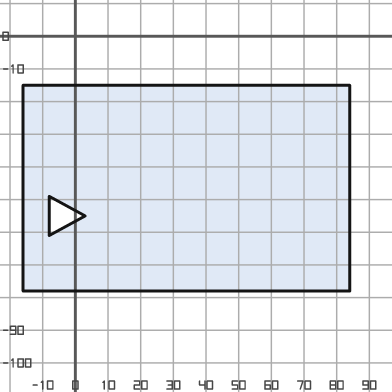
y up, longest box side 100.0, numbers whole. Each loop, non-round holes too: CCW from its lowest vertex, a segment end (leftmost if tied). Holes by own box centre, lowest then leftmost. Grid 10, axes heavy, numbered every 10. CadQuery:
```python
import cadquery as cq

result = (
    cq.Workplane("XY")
    .moveTo(-16.0, -78.0)
    .lineTo(84.0, -78.0)
    .lineTo(84.0, -15.0)
    .lineTo(-16.0, -15.0)
    .close()
    .moveTo(-8.0, -61.0)
    .lineTo(3.0, -55.0)
    .lineTo(-8.0, -49.0)
    .close()
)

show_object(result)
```